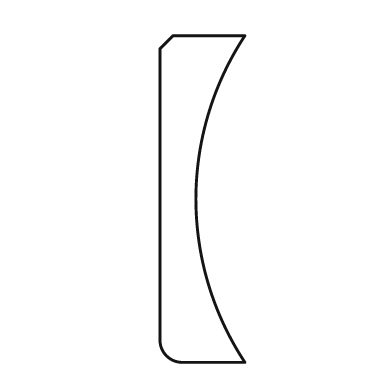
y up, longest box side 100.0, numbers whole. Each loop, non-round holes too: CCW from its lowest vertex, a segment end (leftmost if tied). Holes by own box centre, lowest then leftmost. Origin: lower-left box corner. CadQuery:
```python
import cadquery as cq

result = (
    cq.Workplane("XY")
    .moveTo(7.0, 0.0)
    .lineTo(26.0, 0.0)
    .threePointArc((11.0, 50.0), (26.0, 100.0))
    .lineTo(4.0, 100.0)
    .lineTo(0.0, 96.0)
    .lineTo(0.0, 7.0)
    .threePointArc((2.0, 2.0), (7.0, 0.0))
    .close()
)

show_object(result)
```